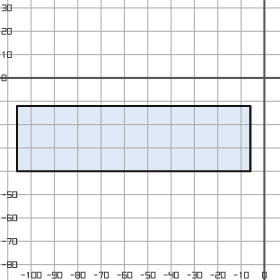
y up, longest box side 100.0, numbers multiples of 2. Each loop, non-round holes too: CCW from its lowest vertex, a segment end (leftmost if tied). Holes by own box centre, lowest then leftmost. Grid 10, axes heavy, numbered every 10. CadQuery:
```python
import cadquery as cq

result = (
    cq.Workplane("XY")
    .moveTo(-106.0, -40.0)
    .lineTo(-6.0, -40.0)
    .lineTo(-6.0, -12.0)
    .lineTo(-106.0, -12.0)
    .close()
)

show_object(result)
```